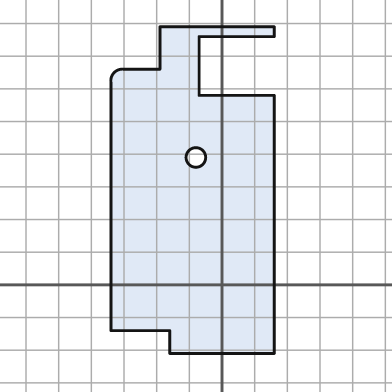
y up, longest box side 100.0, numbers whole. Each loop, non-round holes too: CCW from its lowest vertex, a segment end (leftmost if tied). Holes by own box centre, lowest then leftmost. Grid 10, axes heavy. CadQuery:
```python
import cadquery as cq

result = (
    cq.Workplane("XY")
    .moveTo(-16.0, -21.0)
    .lineTo(16.0, -21.0)
    .lineTo(16.0, 58.0)
    .lineTo(-7.0, 58.0)
    .lineTo(-7.0, 76.0)
    .lineTo(16.0, 76.0)
    .lineTo(16.0, 79.0)
    .lineTo(-19.0, 79.0)
    .lineTo(-19.0, 66.0)
    .lineTo(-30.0, 66.0)
    .threePointArc((-33.0, 65.0), (-34.0, 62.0))
    .lineTo(-34.0, -14.0)
    .lineTo(-16.0, -14.0)
    .close()
    .moveTo(-8.0, 39.0)
    .circle(3.0)
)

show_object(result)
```